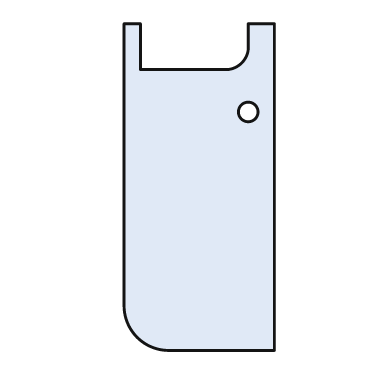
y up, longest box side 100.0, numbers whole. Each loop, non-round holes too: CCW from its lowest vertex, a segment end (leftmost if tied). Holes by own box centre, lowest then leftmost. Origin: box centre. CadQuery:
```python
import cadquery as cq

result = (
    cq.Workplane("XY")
    .moveTo(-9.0, -50.0)
    .lineTo(23.0, -50.0)
    .lineTo(23.0, 50.0)
    .lineTo(15.0, 50.0)
    .lineTo(15.0, 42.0)
    .threePointArc((13.0, 38.0), (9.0, 36.0))
    .lineTo(-18.0, 36.0)
    .lineTo(-18.0, 50.0)
    .lineTo(-23.0, 50.0)
    .lineTo(-23.0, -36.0)
    .threePointArc((-19.0, -46.0), (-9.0, -50.0))
    .close()
    .moveTo(15.0, 23.0)
    .circle(3.0)
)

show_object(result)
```